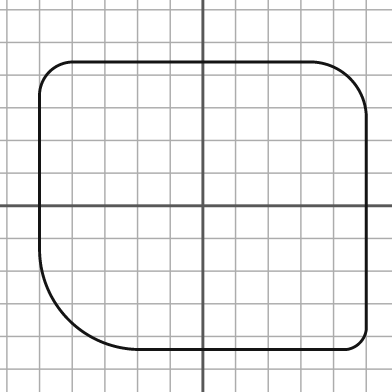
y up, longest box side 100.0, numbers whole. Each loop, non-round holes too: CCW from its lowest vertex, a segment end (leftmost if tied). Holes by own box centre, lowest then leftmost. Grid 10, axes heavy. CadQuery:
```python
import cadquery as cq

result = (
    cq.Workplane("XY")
    .moveTo(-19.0, -44.0)
    .lineTo(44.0, -44.0)
    .threePointArc((48.0, -42.0), (50.0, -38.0))
    .lineTo(50.0, 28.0)
    .threePointArc((45.0, 39.0), (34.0, 44.0))
    .lineTo(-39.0, 44.0)
    .threePointArc((-47.0, 41.0), (-50.0, 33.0))
    .lineTo(-50.0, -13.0)
    .threePointArc((-41.0, -35.0), (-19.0, -44.0))
    .close()
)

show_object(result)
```